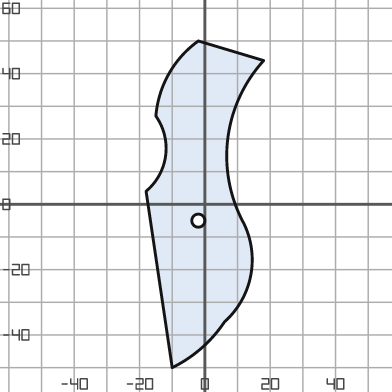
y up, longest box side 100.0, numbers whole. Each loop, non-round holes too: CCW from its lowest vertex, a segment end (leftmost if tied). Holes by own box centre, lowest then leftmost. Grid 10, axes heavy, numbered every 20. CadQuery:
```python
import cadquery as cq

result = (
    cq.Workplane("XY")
    .moveTo(-10.0, -50.0)
    .threePointArc((-1.0, -44.0), (6.0, -36.0))
    .threePointArc((14.0, -22.0), (12.0, -6.0))
    .threePointArc((7.0, 20.0), (18.0, 44.0))
    .lineTo(-2.0, 50.0)
    .threePointArc((-11.0, 40.0), (-15.0, 27.0))
    .threePointArc((-12.0, 15.0), (-18.0, 4.0))
    .close()
    .moveTo(-2.0, -5.0)
    .circle(2.0)
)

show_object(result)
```